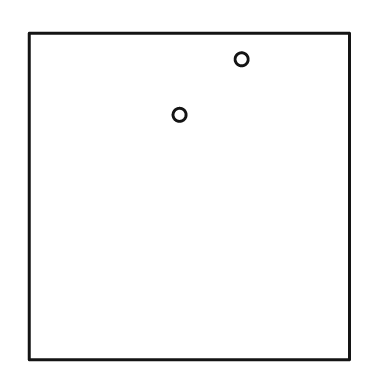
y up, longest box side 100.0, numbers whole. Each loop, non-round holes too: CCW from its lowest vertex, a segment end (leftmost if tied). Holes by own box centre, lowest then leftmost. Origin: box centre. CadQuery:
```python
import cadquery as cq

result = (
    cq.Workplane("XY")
    .moveTo(-49.0, -50.0)
    .lineTo(49.0, -50.0)
    .lineTo(49.0, 50.0)
    .lineTo(-49.0, 50.0)
    .close()
    .moveTo(-3.0, 25.0)
    .circle(2.0)
    .moveTo(16.0, 42.0)
    .circle(2.0)
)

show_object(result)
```